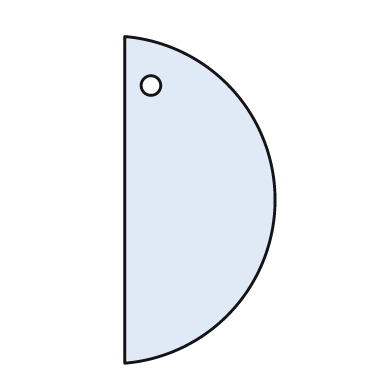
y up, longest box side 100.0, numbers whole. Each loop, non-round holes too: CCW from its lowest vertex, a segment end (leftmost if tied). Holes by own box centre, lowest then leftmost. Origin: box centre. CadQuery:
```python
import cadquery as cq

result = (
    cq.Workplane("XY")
    .moveTo(-23.0, -50.0)
    .threePointArc((23.0, 0.0), (-23.0, 50.0))
    .close()
    .moveTo(-15.0, 35.0)
    .circle(3.0)
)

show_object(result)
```